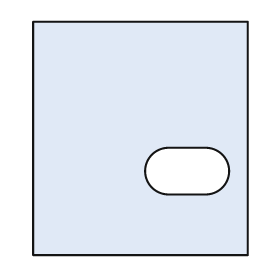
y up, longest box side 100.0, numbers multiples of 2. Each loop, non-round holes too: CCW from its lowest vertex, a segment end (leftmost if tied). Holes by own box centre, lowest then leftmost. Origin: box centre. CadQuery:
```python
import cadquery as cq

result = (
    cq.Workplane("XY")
    .moveTo(-46.0, -50.0)
    .lineTo(46.0, -50.0)
    .lineTo(46.0, 50.0)
    .lineTo(-46.0, 50.0)
    .close()
    .moveTo(12.0, -24.0)
    .lineTo(28.0, -24.0)
    .threePointArc((38.0, -14.0), (28.0, -4.0))
    .lineTo(12.0, -4.0)
    .threePointArc((2.0, -14.0), (12.0, -24.0))
    .close()
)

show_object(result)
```